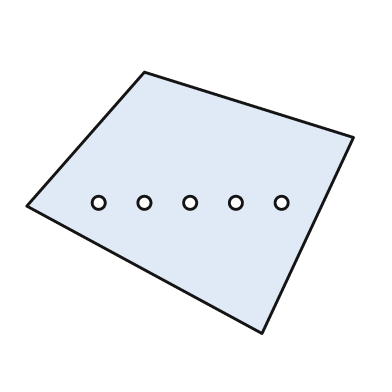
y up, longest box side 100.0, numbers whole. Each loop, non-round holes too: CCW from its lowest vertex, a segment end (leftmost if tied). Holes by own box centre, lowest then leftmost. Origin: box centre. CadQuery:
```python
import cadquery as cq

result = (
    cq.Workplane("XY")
    .moveTo(22.0, -40.0)
    .lineTo(50.0, 20.0)
    .lineTo(-14.0, 40.0)
    .lineTo(-50.0, -1.0)
    .close()
    .moveTo(-28.0, 0.0)
    .circle(2.0)
    .moveTo(-14.0, 0.0)
    .circle(2.0)
    .moveTo(0.0, 0.0)
    .circle(2.0)
    .moveTo(14.0, 0.0)
    .circle(2.0)
    .moveTo(28.0, 0.0)
    .circle(2.0)
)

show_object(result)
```